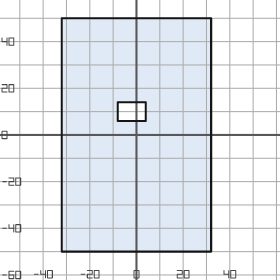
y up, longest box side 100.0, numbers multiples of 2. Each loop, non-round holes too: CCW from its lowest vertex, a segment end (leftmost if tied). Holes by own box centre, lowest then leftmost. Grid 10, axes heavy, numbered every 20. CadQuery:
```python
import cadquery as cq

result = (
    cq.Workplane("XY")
    .moveTo(-32.0, -50.0)
    .lineTo(32.0, -50.0)
    .lineTo(32.0, 50.0)
    .lineTo(-32.0, 50.0)
    .close()
    .moveTo(-8.0, 6.0)
    .lineTo(4.0, 6.0)
    .lineTo(4.0, 14.0)
    .lineTo(-8.0, 14.0)
    .close()
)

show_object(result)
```